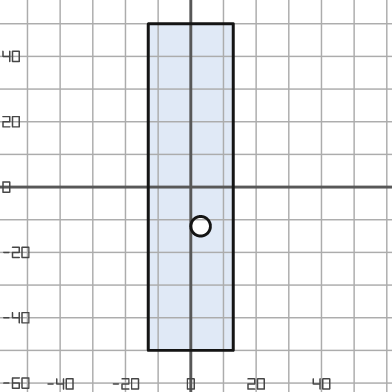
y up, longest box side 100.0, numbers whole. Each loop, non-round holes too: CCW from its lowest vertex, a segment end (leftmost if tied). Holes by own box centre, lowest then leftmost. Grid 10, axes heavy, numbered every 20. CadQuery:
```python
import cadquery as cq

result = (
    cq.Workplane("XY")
    .moveTo(-13.0, -50.0)
    .lineTo(13.0, -50.0)
    .lineTo(13.0, 50.0)
    .lineTo(-13.0, 50.0)
    .close()
    .moveTo(3.0, -12.0)
    .circle(3.0)
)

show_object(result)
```